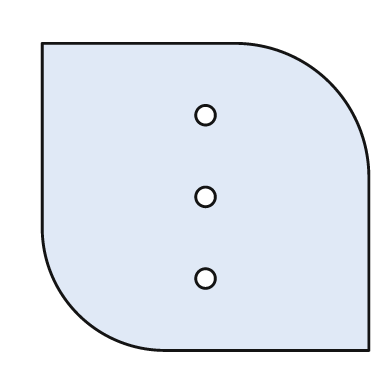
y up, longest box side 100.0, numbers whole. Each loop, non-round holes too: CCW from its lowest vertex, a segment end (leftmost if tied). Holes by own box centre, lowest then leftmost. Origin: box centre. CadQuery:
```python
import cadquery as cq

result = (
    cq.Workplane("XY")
    .moveTo(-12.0, -47.0)
    .lineTo(50.0, -47.0)
    .lineTo(50.0, 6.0)
    .threePointArc((38.0, 35.0), (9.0, 47.0))
    .lineTo(-50.0, 47.0)
    .lineTo(-50.0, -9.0)
    .threePointArc((-39.0, -36.0), (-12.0, -47.0))
    .close()
    .moveTo(0.0, -25.0)
    .circle(3.0)
    .moveTo(0.0, 0.0)
    .circle(3.0)
    .moveTo(0.0, 25.0)
    .circle(3.0)
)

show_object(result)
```